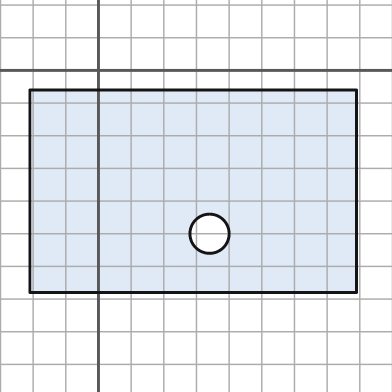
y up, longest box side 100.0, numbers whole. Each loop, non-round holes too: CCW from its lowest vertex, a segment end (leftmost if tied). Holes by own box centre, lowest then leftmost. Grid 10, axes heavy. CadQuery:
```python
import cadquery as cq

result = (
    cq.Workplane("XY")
    .moveTo(-21.0, -68.0)
    .lineTo(79.0, -68.0)
    .lineTo(79.0, -6.0)
    .lineTo(-21.0, -6.0)
    .close()
    .moveTo(34.0, -50.0)
    .circle(6.0)
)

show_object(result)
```